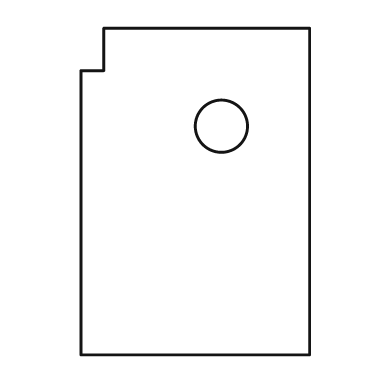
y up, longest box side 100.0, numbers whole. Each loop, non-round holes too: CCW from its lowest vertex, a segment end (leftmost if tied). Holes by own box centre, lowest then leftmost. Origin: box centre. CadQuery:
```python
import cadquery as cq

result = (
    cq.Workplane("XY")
    .moveTo(-35.0, -50.0)
    .lineTo(35.0, -50.0)
    .lineTo(35.0, 50.0)
    .lineTo(-28.0, 50.0)
    .lineTo(-28.0, 37.0)
    .lineTo(-35.0, 37.0)
    .close()
    .moveTo(8.0, 20.0)
    .circle(8.0)
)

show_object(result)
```